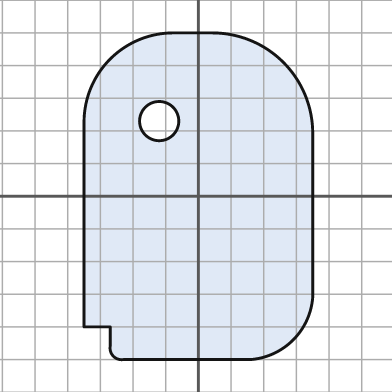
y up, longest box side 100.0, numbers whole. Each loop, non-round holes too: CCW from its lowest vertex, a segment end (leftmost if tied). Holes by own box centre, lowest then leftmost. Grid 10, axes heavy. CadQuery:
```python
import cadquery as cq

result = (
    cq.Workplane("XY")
    .moveTo(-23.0, -50.0)
    .lineTo(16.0, -50.0)
    .threePointArc((29.0, -44.0), (35.0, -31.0))
    .lineTo(35.0, 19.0)
    .threePointArc((26.0, 41.0), (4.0, 50.0))
    .lineTo(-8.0, 50.0)
    .threePointArc((-27.0, 42.0), (-35.0, 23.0))
    .lineTo(-35.0, -40.0)
    .lineTo(-27.0, -40.0)
    .lineTo(-27.0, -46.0)
    .threePointArc((-26.0, -49.0), (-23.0, -50.0))
    .close()
    .moveTo(-12.0, 23.0)
    .circle(6.0)
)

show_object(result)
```